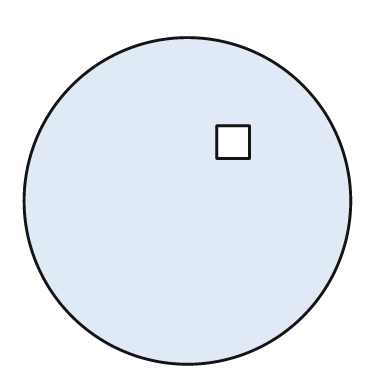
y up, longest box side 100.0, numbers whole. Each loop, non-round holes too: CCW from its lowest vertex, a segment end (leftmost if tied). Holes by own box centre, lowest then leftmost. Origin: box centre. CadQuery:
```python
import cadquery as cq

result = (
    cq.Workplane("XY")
    .moveTo(0.0, 0.0)
    .circle(50.0)
    .moveTo(9.0, 13.0)
    .lineTo(19.0, 13.0)
    .lineTo(19.0, 23.0)
    .lineTo(9.0, 23.0)
    .close()
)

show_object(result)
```